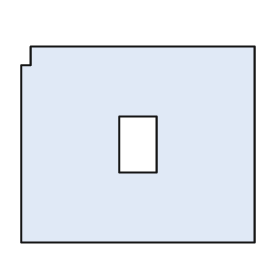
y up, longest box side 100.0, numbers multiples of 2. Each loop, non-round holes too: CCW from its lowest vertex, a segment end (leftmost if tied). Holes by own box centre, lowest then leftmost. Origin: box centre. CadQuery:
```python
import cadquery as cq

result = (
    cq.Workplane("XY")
    .moveTo(-50.0, -42.0)
    .lineTo(50.0, -42.0)
    .lineTo(50.0, 42.0)
    .lineTo(-46.0, 42.0)
    .lineTo(-46.0, 34.0)
    .lineTo(-50.0, 34.0)
    .close()
    .moveTo(-8.0, -12.0)
    .lineTo(8.0, -12.0)
    .lineTo(8.0, 12.0)
    .lineTo(-8.0, 12.0)
    .close()
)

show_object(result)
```